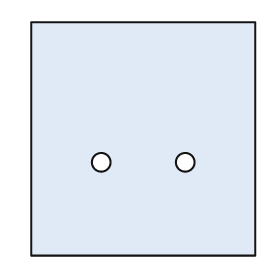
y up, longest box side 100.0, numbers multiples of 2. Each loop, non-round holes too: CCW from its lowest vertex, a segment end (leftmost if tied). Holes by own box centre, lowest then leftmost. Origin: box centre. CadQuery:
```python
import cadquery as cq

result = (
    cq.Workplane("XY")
    .moveTo(-48.0, -50.0)
    .lineTo(48.0, -50.0)
    .lineTo(48.0, 50.0)
    .lineTo(-48.0, 50.0)
    .close()
    .moveTo(-18.0, -10.0)
    .circle(4.0)
    .moveTo(18.0, -10.0)
    .circle(4.0)
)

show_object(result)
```